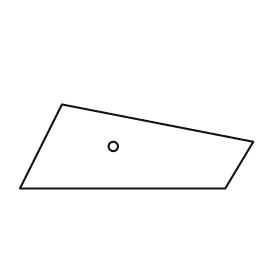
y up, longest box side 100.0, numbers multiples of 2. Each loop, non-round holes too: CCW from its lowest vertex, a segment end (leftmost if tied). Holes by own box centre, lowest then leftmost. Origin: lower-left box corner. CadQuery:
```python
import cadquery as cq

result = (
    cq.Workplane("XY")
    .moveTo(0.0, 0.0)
    .lineTo(88.0, 0.0)
    .lineTo(100.0, 20.0)
    .lineTo(18.0, 36.0)
    .close()
    .moveTo(40.0, 18.0)
    .circle(2.0)
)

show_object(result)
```